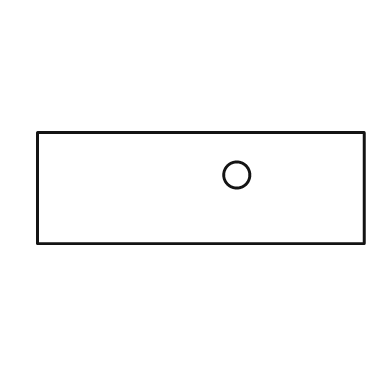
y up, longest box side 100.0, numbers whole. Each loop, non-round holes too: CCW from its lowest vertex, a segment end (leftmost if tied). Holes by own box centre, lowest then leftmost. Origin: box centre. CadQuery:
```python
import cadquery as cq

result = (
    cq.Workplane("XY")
    .moveTo(-50.0, -17.0)
    .lineTo(50.0, -17.0)
    .lineTo(50.0, 17.0)
    .lineTo(-50.0, 17.0)
    .close()
    .moveTo(11.0, 4.0)
    .circle(4.0)
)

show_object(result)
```